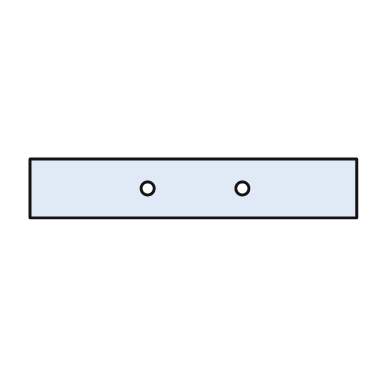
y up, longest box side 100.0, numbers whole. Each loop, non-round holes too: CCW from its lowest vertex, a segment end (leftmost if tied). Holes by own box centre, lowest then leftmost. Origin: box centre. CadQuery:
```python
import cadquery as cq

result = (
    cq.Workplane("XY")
    .moveTo(-50.0, -9.0)
    .lineTo(50.0, -9.0)
    .lineTo(50.0, 9.0)
    .lineTo(-50.0, 9.0)
    .close()
    .moveTo(-14.0, 0.0)
    .circle(2.0)
    .moveTo(15.0, 0.0)
    .circle(2.0)
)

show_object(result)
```